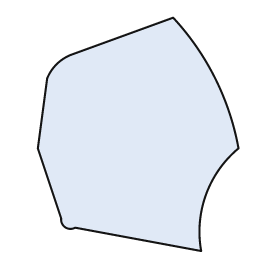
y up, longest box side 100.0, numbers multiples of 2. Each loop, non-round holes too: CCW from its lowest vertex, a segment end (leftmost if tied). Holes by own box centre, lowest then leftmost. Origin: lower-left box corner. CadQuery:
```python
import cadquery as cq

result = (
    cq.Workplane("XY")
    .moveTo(70.0, 0.0)
    .threePointArc((72.0, 24.0), (86.0, 44.0))
    .threePointArc((76.0, 74.0), (58.0, 100.0))
    .lineTo(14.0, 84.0)
    .threePointArc((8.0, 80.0), (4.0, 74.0))
    .lineTo(0.0, 44.0)
    .lineTo(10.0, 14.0)
    .threePointArc((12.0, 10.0), (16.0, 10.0))
    .close()
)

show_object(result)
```